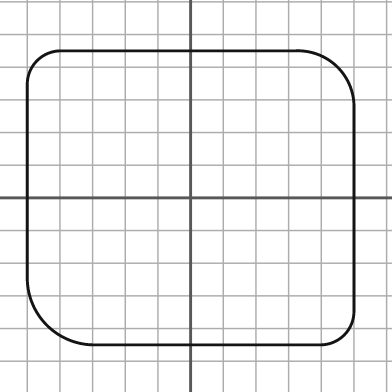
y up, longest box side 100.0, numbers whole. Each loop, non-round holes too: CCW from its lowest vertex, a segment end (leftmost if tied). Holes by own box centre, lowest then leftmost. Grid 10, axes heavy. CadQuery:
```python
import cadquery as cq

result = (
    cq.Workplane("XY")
    .moveTo(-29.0, -45.0)
    .lineTo(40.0, -45.0)
    .threePointArc((47.0, -42.0), (50.0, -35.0))
    .lineTo(50.0, 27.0)
    .threePointArc((45.0, 40.0), (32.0, 45.0))
    .lineTo(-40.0, 45.0)
    .threePointArc((-47.0, 42.0), (-50.0, 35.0))
    .lineTo(-50.0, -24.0)
    .threePointArc((-44.0, -39.0), (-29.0, -45.0))
    .close()
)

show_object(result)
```